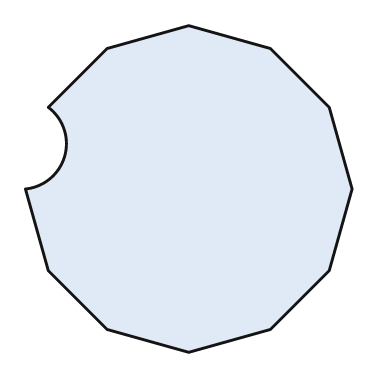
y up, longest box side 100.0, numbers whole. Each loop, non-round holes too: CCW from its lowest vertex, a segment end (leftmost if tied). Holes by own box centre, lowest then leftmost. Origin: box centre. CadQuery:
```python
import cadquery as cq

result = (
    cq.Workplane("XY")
    .moveTo(0.0, -50.0)
    .lineTo(25.0, -43.0)
    .lineTo(43.0, -25.0)
    .lineTo(50.0, 0.0)
    .lineTo(43.0, 25.0)
    .lineTo(25.0, 43.0)
    .lineTo(0.0, 50.0)
    .lineTo(-25.0, 43.0)
    .lineTo(-43.0, 25.0)
    .threePointArc((-38.0, 10.0), (-50.0, 0.0))
    .lineTo(-43.0, -25.0)
    .lineTo(-25.0, -43.0)
    .close()
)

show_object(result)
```